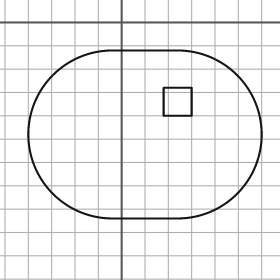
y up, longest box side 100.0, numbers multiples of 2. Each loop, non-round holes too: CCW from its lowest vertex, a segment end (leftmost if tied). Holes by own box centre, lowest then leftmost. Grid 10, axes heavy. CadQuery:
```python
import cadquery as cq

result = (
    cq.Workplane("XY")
    .moveTo(-4.0, -84.0)
    .lineTo(24.0, -84.0)
    .threePointArc((60.0, -48.0), (24.0, -12.0))
    .lineTo(-4.0, -12.0)
    .threePointArc((-40.0, -48.0), (-4.0, -84.0))
    .close()
    .moveTo(18.0, -40.0)
    .lineTo(30.0, -40.0)
    .lineTo(30.0, -28.0)
    .lineTo(18.0, -28.0)
    .close()
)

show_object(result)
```